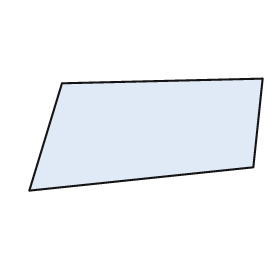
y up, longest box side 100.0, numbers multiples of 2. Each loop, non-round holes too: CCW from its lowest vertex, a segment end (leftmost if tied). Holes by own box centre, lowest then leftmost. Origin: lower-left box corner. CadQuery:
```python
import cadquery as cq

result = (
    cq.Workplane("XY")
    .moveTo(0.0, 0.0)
    .lineTo(96.0, 10.0)
    .lineTo(100.0, 48.0)
    .lineTo(14.0, 46.0)
    .close()
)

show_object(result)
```